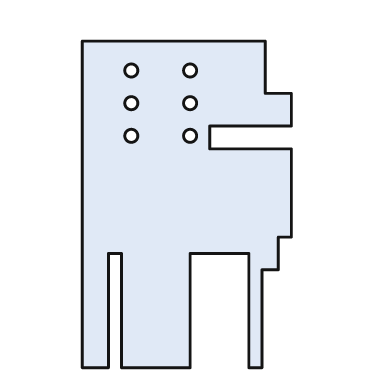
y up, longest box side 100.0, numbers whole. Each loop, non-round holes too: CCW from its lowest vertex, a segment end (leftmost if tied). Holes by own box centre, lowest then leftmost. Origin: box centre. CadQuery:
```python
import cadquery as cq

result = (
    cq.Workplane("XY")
    .moveTo(-32.0, -50.0)
    .lineTo(-24.0, -50.0)
    .lineTo(-24.0, -15.0)
    .lineTo(-20.0, -15.0)
    .lineTo(-20.0, -50.0)
    .lineTo(1.0, -50.0)
    .lineTo(1.0, -15.0)
    .lineTo(19.0, -15.0)
    .lineTo(19.0, -50.0)
    .lineTo(23.0, -50.0)
    .lineTo(23.0, -20.0)
    .lineTo(28.0, -20.0)
    .lineTo(28.0, -10.0)
    .lineTo(32.0, -10.0)
    .lineTo(32.0, 17.0)
    .lineTo(7.0, 17.0)
    .lineTo(7.0, 24.0)
    .lineTo(32.0, 24.0)
    .lineTo(32.0, 34.0)
    .lineTo(24.0, 34.0)
    .lineTo(24.0, 50.0)
    .lineTo(-32.0, 50.0)
    .close()
    .moveTo(-17.0, 21.0)
    .circle(2.0)
    .moveTo(1.0, 21.0)
    .circle(2.0)
    .moveTo(-17.0, 31.0)
    .circle(2.0)
    .moveTo(1.0, 31.0)
    .circle(2.0)
    .moveTo(-17.0, 41.0)
    .circle(2.0)
    .moveTo(1.0, 41.0)
    .circle(2.0)
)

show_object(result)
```